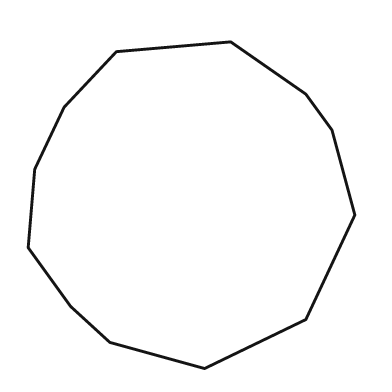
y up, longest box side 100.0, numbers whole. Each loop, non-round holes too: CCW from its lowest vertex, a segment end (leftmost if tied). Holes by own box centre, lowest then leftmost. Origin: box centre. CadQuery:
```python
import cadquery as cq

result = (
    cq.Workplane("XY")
    .moveTo(4.0, -50.0)
    .lineTo(35.0, -35.0)
    .lineTo(50.0, -3.0)
    .lineTo(43.0, 23.0)
    .lineTo(35.0, 34.0)
    .lineTo(12.0, 50.0)
    .lineTo(-23.0, 47.0)
    .lineTo(-39.0, 30.0)
    .lineTo(-48.0, 11.0)
    .lineTo(-50.0, -13.0)
    .lineTo(-37.0, -31.0)
    .lineTo(-25.0, -42.0)
    .close()
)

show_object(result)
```